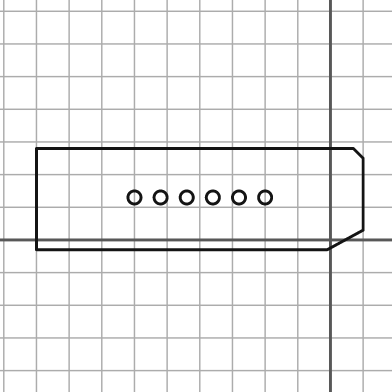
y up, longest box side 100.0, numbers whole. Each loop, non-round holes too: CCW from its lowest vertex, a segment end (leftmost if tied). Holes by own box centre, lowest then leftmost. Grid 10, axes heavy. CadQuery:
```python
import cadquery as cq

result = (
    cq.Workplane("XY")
    .moveTo(-90.0, -3.0)
    .lineTo(-1.0, -3.0)
    .lineTo(10.0, 3.0)
    .lineTo(10.0, 25.0)
    .lineTo(7.0, 28.0)
    .lineTo(-90.0, 28.0)
    .close()
    .moveTo(-60.0, 13.0)
    .circle(2.0)
    .moveTo(-52.0, 13.0)
    .circle(2.0)
    .moveTo(-44.0, 13.0)
    .circle(2.0)
    .moveTo(-36.0, 13.0)
    .circle(2.0)
    .moveTo(-28.0, 13.0)
    .circle(2.0)
    .moveTo(-20.0, 13.0)
    .circle(2.0)
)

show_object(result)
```